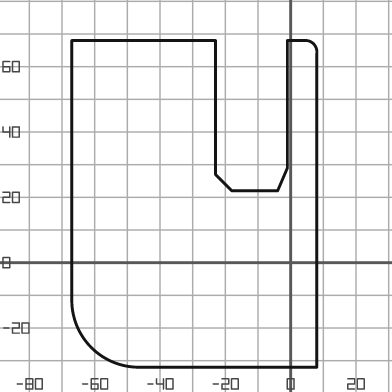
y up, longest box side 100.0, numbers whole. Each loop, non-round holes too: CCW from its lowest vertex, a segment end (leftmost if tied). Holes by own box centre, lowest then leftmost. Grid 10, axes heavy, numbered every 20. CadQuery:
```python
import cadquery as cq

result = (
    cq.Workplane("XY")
    .moveTo(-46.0, -32.0)
    .lineTo(8.0, -32.0)
    .lineTo(8.0, 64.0)
    .threePointArc((7.0, 67.0), (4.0, 68.0))
    .lineTo(-1.0, 68.0)
    .lineTo(-1.0, 29.0)
    .lineTo(-4.0, 22.0)
    .lineTo(-18.0, 22.0)
    .lineTo(-23.0, 27.0)
    .lineTo(-23.0, 68.0)
    .lineTo(-67.0, 68.0)
    .lineTo(-67.0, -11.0)
    .threePointArc((-61.0, -26.0), (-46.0, -32.0))
    .close()
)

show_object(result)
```